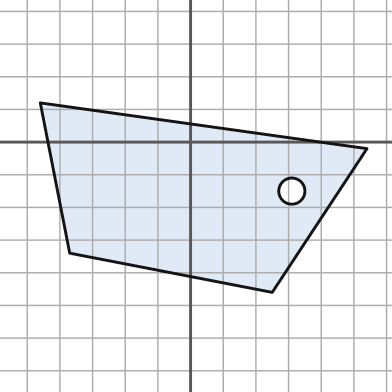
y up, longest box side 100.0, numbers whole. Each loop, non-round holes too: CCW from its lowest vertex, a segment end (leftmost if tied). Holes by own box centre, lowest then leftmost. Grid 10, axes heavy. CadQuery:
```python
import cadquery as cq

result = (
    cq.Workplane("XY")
    .moveTo(25.0, -46.0)
    .lineTo(54.0, -2.0)
    .lineTo(-46.0, 12.0)
    .lineTo(-37.0, -34.0)
    .close()
    .moveTo(31.0, -15.0)
    .circle(4.0)
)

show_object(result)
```